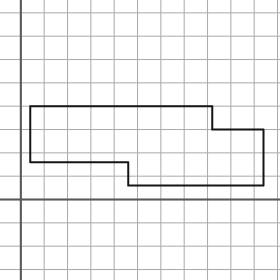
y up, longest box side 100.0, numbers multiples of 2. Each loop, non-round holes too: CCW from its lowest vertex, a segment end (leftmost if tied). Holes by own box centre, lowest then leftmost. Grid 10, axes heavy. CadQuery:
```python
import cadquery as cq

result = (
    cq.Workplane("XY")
    .moveTo(46.0, 6.0)
    .lineTo(104.0, 6.0)
    .lineTo(104.0, 30.0)
    .lineTo(82.0, 30.0)
    .lineTo(82.0, 40.0)
    .lineTo(4.0, 40.0)
    .lineTo(4.0, 16.0)
    .lineTo(46.0, 16.0)
    .close()
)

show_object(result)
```